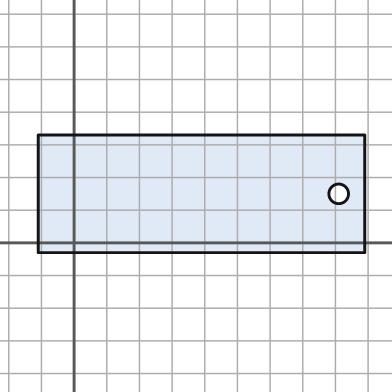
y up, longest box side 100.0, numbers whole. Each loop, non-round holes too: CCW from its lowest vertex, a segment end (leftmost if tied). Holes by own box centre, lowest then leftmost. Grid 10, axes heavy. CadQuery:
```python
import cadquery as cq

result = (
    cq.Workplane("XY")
    .moveTo(-11.0, -3.0)
    .lineTo(89.0, -3.0)
    .lineTo(89.0, 33.0)
    .lineTo(-11.0, 33.0)
    .close()
    .moveTo(81.0, 15.0)
    .circle(3.0)
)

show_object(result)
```